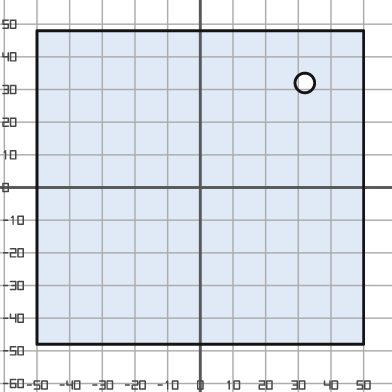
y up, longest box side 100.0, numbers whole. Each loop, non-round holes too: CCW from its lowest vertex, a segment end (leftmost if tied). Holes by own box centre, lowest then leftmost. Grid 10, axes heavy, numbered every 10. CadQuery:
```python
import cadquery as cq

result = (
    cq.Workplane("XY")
    .moveTo(-50.0, -48.0)
    .lineTo(50.0, -48.0)
    .lineTo(50.0, 48.0)
    .lineTo(-50.0, 48.0)
    .close()
    .moveTo(32.0, 32.0)
    .circle(3.0)
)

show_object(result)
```